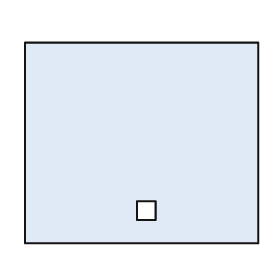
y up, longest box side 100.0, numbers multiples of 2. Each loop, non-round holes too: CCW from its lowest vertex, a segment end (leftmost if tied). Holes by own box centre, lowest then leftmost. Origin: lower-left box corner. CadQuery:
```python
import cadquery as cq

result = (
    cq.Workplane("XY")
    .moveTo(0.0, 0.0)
    .lineTo(100.0, 0.0)
    .lineTo(100.0, 86.0)
    .lineTo(0.0, 86.0)
    .close()
    .moveTo(48.0, 10.0)
    .lineTo(56.0, 10.0)
    .lineTo(56.0, 18.0)
    .lineTo(48.0, 18.0)
    .close()
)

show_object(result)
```